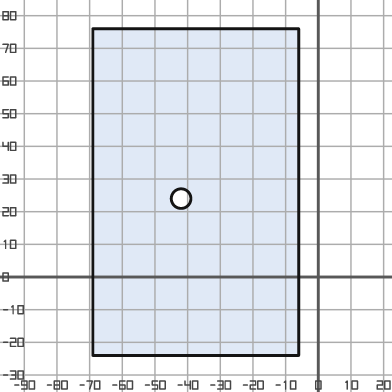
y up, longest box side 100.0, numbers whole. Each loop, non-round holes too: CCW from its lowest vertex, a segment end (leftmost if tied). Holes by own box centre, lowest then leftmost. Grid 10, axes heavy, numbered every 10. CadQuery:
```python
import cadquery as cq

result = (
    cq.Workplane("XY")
    .moveTo(-69.0, -24.0)
    .lineTo(-6.0, -24.0)
    .lineTo(-6.0, 76.0)
    .lineTo(-69.0, 76.0)
    .close()
    .moveTo(-42.0, 24.0)
    .circle(3.0)
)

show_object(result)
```